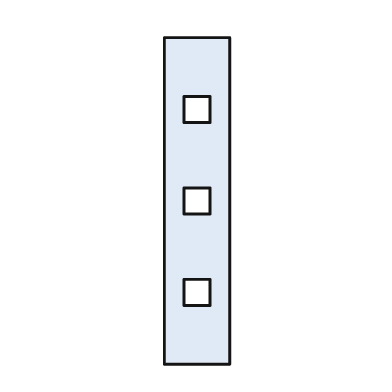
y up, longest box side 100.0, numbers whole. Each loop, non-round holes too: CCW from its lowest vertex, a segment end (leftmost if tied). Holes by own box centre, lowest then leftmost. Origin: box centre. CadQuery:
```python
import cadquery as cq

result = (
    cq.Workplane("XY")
    .moveTo(-10.0, -50.0)
    .lineTo(10.0, -50.0)
    .lineTo(10.0, 50.0)
    .lineTo(-10.0, 50.0)
    .close()
    .moveTo(-4.0, -32.0)
    .lineTo(4.0, -32.0)
    .lineTo(4.0, -24.0)
    .lineTo(-4.0, -24.0)
    .close()
    .moveTo(-4.0, -4.0)
    .lineTo(4.0, -4.0)
    .lineTo(4.0, 4.0)
    .lineTo(-4.0, 4.0)
    .close()
    .moveTo(-4.0, 24.0)
    .lineTo(4.0, 24.0)
    .lineTo(4.0, 32.0)
    .lineTo(-4.0, 32.0)
    .close()
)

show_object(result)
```